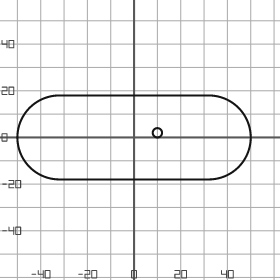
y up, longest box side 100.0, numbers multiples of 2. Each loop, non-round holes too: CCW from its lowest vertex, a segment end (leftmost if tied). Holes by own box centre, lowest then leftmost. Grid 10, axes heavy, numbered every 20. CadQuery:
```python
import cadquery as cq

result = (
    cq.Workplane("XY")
    .moveTo(-32.0, -18.0)
    .lineTo(32.0, -18.0)
    .threePointArc((50.0, 0.0), (32.0, 18.0))
    .lineTo(-32.0, 18.0)
    .threePointArc((-50.0, 0.0), (-32.0, -18.0))
    .close()
    .moveTo(10.0, 2.0)
    .circle(2.0)
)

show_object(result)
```